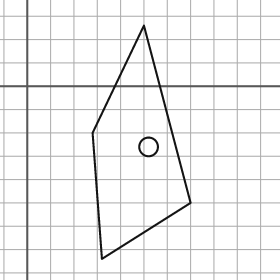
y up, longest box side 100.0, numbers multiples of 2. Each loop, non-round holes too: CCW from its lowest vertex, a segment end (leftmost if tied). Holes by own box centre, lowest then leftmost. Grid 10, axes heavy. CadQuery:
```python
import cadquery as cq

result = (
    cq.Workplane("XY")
    .moveTo(32.0, -74.0)
    .lineTo(70.0, -50.0)
    .lineTo(50.0, 26.0)
    .lineTo(28.0, -20.0)
    .close()
    .moveTo(52.0, -26.0)
    .circle(4.0)
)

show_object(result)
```